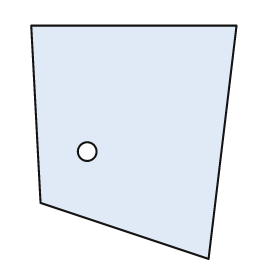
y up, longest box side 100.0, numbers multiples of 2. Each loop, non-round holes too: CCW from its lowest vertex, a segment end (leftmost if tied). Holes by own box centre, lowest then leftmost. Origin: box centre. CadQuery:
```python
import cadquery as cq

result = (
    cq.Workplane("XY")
    .moveTo(32.0, -50.0)
    .lineTo(44.0, 50.0)
    .lineTo(-44.0, 50.0)
    .lineTo(-40.0, -26.0)
    .close()
    .moveTo(-20.0, -4.0)
    .circle(4.0)
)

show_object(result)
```